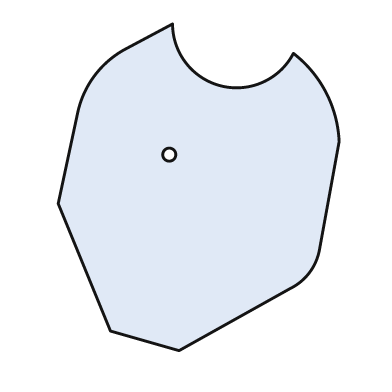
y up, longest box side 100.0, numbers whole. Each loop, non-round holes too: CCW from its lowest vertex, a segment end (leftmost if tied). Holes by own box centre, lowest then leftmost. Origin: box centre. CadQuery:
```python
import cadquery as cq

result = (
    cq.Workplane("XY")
    .moveTo(-6.0, -50.0)
    .lineTo(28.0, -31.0)
    .threePointArc((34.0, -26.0), (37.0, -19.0))
    .lineTo(43.0, 14.0)
    .threePointArc((39.0, 29.0), (29.0, 41.0))
    .threePointArc((7.0, 31.0), (-8.0, 50.0))
    .lineTo(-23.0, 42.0)
    .threePointArc((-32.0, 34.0), (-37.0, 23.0))
    .lineTo(-43.0, -5.0)
    .lineTo(-27.0, -44.0)
    .close()
    .moveTo(-9.0, 10.0)
    .circle(2.0)
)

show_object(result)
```